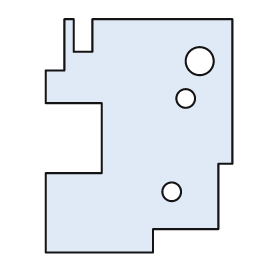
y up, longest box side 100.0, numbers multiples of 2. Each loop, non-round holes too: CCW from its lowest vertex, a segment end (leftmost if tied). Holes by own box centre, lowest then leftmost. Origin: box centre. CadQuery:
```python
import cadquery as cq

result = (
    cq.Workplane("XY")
    .moveTo(-40.0, -50.0)
    .lineTo(6.0, -50.0)
    .lineTo(6.0, -40.0)
    .lineTo(34.0, -40.0)
    .lineTo(34.0, -12.0)
    .lineTo(40.0, -12.0)
    .lineTo(40.0, 50.0)
    .lineTo(-20.0, 50.0)
    .lineTo(-20.0, 36.0)
    .lineTo(-28.0, 36.0)
    .lineTo(-28.0, 50.0)
    .lineTo(-32.0, 50.0)
    .lineTo(-32.0, 28.0)
    .lineTo(-40.0, 28.0)
    .lineTo(-40.0, 14.0)
    .lineTo(-16.0, 14.0)
    .lineTo(-16.0, -16.0)
    .lineTo(-40.0, -16.0)
    .close()
    .moveTo(14.0, -24.0)
    .circle(4.0)
    .moveTo(20.0, 16.0)
    .circle(4.0)
    .moveTo(26.0, 32.0)
    .circle(6.0)
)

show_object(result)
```